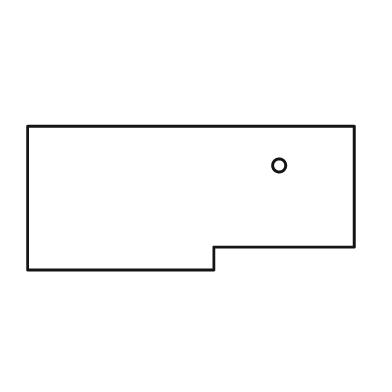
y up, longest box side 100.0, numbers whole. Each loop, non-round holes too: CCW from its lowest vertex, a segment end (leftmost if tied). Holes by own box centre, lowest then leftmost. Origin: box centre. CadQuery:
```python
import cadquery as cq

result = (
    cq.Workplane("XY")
    .moveTo(-50.0, -22.0)
    .lineTo(7.0, -22.0)
    .lineTo(7.0, -15.0)
    .lineTo(50.0, -15.0)
    .lineTo(50.0, 22.0)
    .lineTo(-50.0, 22.0)
    .close()
    .moveTo(27.0, 10.0)
    .circle(2.0)
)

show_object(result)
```